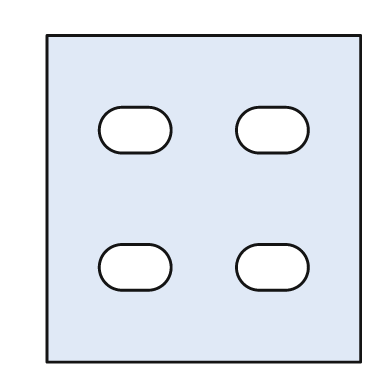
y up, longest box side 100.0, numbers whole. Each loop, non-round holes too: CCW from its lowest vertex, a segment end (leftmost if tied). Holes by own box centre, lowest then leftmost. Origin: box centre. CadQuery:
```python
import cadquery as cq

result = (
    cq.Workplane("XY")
    .moveTo(-48.0, -50.0)
    .lineTo(48.0, -50.0)
    .lineTo(48.0, 50.0)
    .lineTo(-48.0, 50.0)
    .close()
    .moveTo(-25.0, -28.0)
    .lineTo(-17.0, -28.0)
    .threePointArc((-10.0, -21.0), (-17.0, -14.0))
    .lineTo(-25.0, -14.0)
    .threePointArc((-32.0, -21.0), (-25.0, -28.0))
    .close()
    .moveTo(17.0, -28.0)
    .lineTo(25.0, -28.0)
    .threePointArc((32.0, -21.0), (25.0, -14.0))
    .lineTo(17.0, -14.0)
    .threePointArc((10.0, -21.0), (17.0, -28.0))
    .close()
    .moveTo(-25.0, 14.0)
    .lineTo(-17.0, 14.0)
    .threePointArc((-10.0, 21.0), (-17.0, 28.0))
    .lineTo(-25.0, 28.0)
    .threePointArc((-32.0, 21.0), (-25.0, 14.0))
    .close()
    .moveTo(17.0, 14.0)
    .lineTo(25.0, 14.0)
    .threePointArc((32.0, 21.0), (25.0, 28.0))
    .lineTo(17.0, 28.0)
    .threePointArc((10.0, 21.0), (17.0, 14.0))
    .close()
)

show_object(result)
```